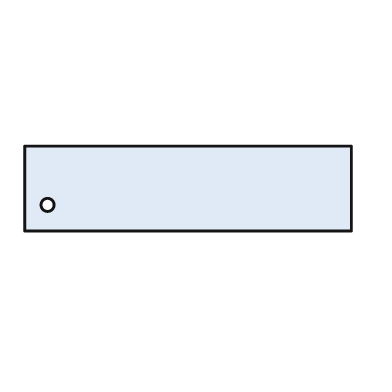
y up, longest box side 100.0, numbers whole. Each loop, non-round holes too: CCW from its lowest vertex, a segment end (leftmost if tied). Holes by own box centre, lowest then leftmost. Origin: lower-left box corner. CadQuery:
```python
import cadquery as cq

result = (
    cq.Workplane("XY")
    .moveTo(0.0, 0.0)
    .lineTo(100.0, 0.0)
    .lineTo(100.0, 26.0)
    .lineTo(0.0, 26.0)
    .close()
    .moveTo(7.0, 8.0)
    .circle(2.0)
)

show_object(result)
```